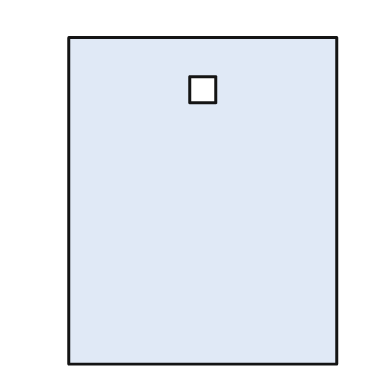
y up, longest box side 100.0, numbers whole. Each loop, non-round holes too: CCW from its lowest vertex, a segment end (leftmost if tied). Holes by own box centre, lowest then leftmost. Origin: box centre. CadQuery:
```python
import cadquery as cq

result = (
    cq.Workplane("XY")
    .moveTo(-41.0, -50.0)
    .lineTo(41.0, -50.0)
    .lineTo(41.0, 50.0)
    .lineTo(-41.0, 50.0)
    .close()
    .moveTo(-4.0, 30.0)
    .lineTo(4.0, 30.0)
    .lineTo(4.0, 38.0)
    .lineTo(-4.0, 38.0)
    .close()
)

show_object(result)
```